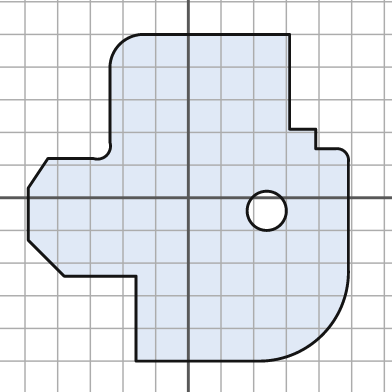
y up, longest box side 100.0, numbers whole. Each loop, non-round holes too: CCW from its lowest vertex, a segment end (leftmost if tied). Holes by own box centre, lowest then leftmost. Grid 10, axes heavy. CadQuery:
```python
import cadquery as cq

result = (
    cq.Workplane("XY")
    .moveTo(-16.0, -50.0)
    .lineTo(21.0, -50.0)
    .threePointArc((41.0, -42.0), (49.0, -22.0))
    .lineTo(49.0, 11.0)
    .threePointArc((48.0, 14.0), (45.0, 15.0))
    .lineTo(39.0, 15.0)
    .lineTo(39.0, 21.0)
    .lineTo(31.0, 21.0)
    .lineTo(31.0, 50.0)
    .lineTo(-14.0, 50.0)
    .threePointArc((-21.0, 47.0), (-24.0, 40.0))
    .lineTo(-24.0, 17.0)
    .threePointArc((-25.0, 13.0), (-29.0, 12.0))
    .lineTo(-43.0, 12.0)
    .lineTo(-49.0, 3.0)
    .lineTo(-49.0, -13.0)
    .lineTo(-38.0, -24.0)
    .lineTo(-16.0, -24.0)
    .close()
    .moveTo(24.0, -4.0)
    .circle(6.0)
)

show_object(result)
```